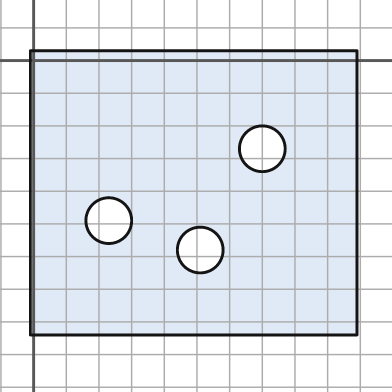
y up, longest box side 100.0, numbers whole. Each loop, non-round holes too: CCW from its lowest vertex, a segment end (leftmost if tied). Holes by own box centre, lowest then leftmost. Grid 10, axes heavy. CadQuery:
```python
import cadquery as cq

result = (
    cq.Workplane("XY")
    .moveTo(-1.0, -84.0)
    .lineTo(99.0, -84.0)
    .lineTo(99.0, 3.0)
    .lineTo(-1.0, 3.0)
    .close()
    .moveTo(51.0, -58.0)
    .circle(7.0)
    .moveTo(23.0, -49.0)
    .circle(7.0)
    .moveTo(70.0, -27.0)
    .circle(7.0)
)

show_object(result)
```